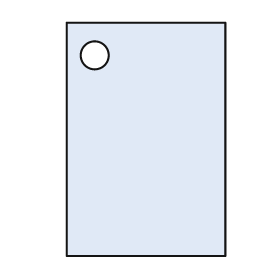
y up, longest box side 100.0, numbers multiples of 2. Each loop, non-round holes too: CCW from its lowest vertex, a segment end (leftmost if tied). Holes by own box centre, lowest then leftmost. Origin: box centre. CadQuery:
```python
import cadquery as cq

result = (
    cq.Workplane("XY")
    .moveTo(-34.0, -50.0)
    .lineTo(34.0, -50.0)
    .lineTo(34.0, 50.0)
    .lineTo(-34.0, 50.0)
    .close()
    .moveTo(-22.0, 36.0)
    .circle(6.0)
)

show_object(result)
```